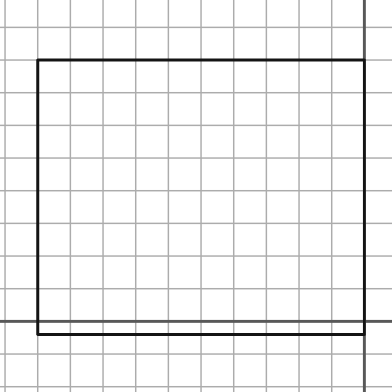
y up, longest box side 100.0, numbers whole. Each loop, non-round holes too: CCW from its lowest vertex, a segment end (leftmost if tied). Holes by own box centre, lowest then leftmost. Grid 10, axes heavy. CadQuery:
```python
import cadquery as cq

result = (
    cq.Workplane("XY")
    .moveTo(-100.0, -4.0)
    .lineTo(0.0, -4.0)
    .lineTo(0.0, 80.0)
    .lineTo(-100.0, 80.0)
    .close()
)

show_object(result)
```